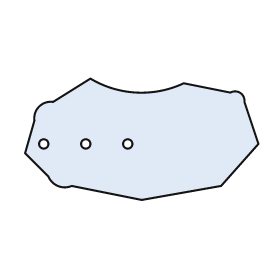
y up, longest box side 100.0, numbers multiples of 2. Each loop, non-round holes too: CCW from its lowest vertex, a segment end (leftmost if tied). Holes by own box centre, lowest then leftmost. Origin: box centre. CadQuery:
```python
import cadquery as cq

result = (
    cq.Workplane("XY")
    .moveTo(0.0, -26.0)
    .lineTo(34.0, -20.0)
    .lineTo(50.0, -2.0)
    .lineTo(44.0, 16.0)
    .threePointArc((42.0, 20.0), (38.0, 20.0))
    .lineTo(18.0, 24.0)
    .threePointArc((-2.0, 20.0), (-22.0, 26.0))
    .lineTo(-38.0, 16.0)
    .threePointArc((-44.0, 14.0), (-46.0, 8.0))
    .lineTo(-50.0, -6.0)
    .lineTo(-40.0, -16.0)
    .threePointArc((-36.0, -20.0), (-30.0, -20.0))
    .close()
    .moveTo(-42.0, -2.0)
    .circle(2.0)
    .moveTo(-24.0, -2.0)
    .circle(2.0)
    .moveTo(-6.0, -2.0)
    .circle(2.0)
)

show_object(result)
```